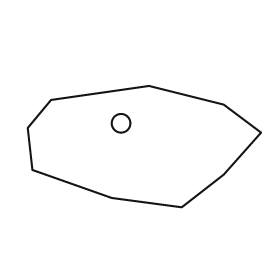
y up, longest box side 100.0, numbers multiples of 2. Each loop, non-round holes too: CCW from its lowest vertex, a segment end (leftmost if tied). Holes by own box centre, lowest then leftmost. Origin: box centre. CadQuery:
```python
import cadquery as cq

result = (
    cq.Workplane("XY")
    .moveTo(16.0, -26.0)
    .lineTo(34.0, -12.0)
    .lineTo(50.0, 6.0)
    .lineTo(34.0, 18.0)
    .lineTo(2.0, 26.0)
    .lineTo(-40.0, 20.0)
    .lineTo(-50.0, 8.0)
    .lineTo(-48.0, -10.0)
    .lineTo(-14.0, -22.0)
    .close()
    .moveTo(-10.0, 10.0)
    .circle(4.0)
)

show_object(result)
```